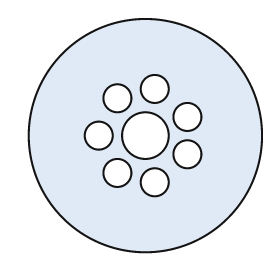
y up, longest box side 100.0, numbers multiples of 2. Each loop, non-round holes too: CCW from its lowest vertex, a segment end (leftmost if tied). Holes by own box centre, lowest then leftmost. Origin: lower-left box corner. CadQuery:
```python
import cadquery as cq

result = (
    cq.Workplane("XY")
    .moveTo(50.0, 50.0)
    .circle(50.0)
    .moveTo(54.0, 30.0)
    .circle(6.0)
    .moveTo(38.0, 34.0)
    .circle(6.0)
    .moveTo(68.0, 42.0)
    .circle(6.0)
    .moveTo(30.0, 50.0)
    .circle(6.0)
    .moveTo(50.0, 50.0)
    .circle(10.0)
    .moveTo(68.0, 58.0)
    .circle(6.0)
    .moveTo(38.0, 66.0)
    .circle(6.0)
    .moveTo(54.0, 70.0)
    .circle(6.0)
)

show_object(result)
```